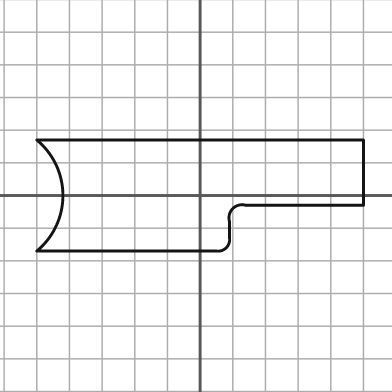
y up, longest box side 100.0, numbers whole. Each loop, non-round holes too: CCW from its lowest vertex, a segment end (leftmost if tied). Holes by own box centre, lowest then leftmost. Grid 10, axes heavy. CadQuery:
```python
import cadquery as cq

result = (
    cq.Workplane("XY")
    .moveTo(-50.0, -17.0)
    .lineTo(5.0, -17.0)
    .threePointArc((8.0, -16.0), (9.0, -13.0))
    .lineTo(9.0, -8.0)
    .threePointArc((10.0, -4.0), (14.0, -3.0))
    .lineTo(50.0, -3.0)
    .lineTo(50.0, 17.0)
    .lineTo(-50.0, 17.0)
    .threePointArc((-42.0, 0.0), (-50.0, -17.0))
    .close()
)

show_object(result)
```